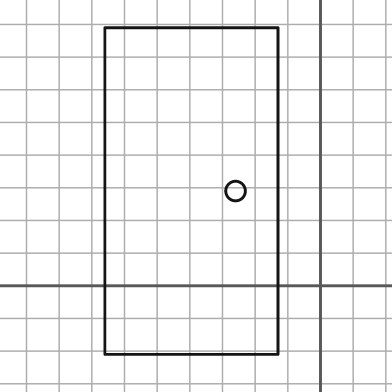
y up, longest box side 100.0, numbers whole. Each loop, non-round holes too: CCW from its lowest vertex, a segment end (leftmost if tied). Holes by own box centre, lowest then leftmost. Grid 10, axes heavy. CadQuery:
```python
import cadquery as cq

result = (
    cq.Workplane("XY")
    .moveTo(-66.0, -21.0)
    .lineTo(-13.0, -21.0)
    .lineTo(-13.0, 79.0)
    .lineTo(-66.0, 79.0)
    .close()
    .moveTo(-26.0, 29.0)
    .circle(3.0)
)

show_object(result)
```